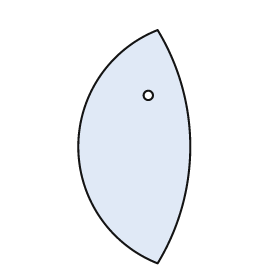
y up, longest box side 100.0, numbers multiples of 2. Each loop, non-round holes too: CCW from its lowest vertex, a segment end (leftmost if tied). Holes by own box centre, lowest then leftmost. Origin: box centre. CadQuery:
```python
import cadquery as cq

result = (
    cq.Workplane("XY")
    .moveTo(10.0, -50.0)
    .threePointArc((24.0, 0.0), (10.0, 50.0))
    .threePointArc((-24.0, 0.0), (10.0, -50.0))
    .close()
    .moveTo(6.0, 22.0)
    .circle(2.0)
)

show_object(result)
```